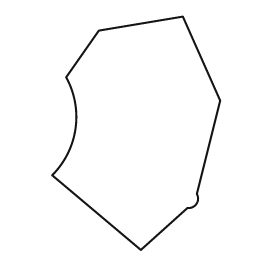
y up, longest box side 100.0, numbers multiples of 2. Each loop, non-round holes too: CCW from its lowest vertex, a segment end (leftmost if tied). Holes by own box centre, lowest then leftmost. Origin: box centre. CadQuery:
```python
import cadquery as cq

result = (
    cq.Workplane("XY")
    .moveTo(2.0, -50.0)
    .lineTo(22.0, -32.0)
    .threePointArc((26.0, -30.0), (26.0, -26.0))
    .lineTo(36.0, 14.0)
    .lineTo(20.0, 50.0)
    .lineTo(-16.0, 44.0)
    .lineTo(-30.0, 24.0)
    .threePointArc((-26.0, 2.0), (-36.0, -18.0))
    .close()
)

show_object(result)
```